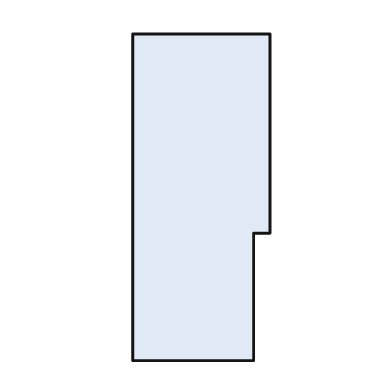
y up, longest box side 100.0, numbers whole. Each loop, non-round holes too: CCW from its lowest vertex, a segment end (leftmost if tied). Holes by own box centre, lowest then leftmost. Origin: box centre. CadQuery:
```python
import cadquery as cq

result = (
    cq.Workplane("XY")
    .moveTo(-21.0, -50.0)
    .lineTo(16.0, -50.0)
    .lineTo(16.0, -11.0)
    .lineTo(21.0, -11.0)
    .lineTo(21.0, 50.0)
    .lineTo(-21.0, 50.0)
    .close()
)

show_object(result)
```